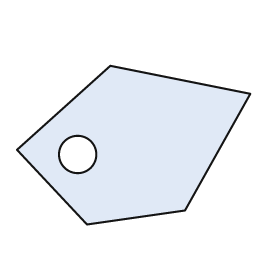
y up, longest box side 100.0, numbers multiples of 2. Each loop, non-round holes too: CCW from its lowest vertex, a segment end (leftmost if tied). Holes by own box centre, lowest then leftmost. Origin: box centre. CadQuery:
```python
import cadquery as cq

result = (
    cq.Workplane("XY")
    .moveTo(-20.0, -34.0)
    .lineTo(22.0, -28.0)
    .lineTo(50.0, 22.0)
    .lineTo(-10.0, 34.0)
    .lineTo(-50.0, -2.0)
    .close()
    .moveTo(-24.0, -4.0)
    .circle(8.0)
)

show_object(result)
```